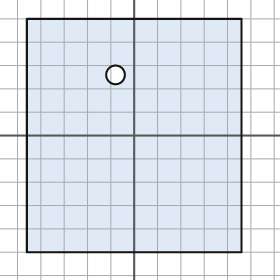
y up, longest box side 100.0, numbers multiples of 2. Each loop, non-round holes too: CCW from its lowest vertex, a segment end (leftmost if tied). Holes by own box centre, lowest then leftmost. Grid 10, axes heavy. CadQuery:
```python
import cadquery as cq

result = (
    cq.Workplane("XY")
    .moveTo(-46.0, -50.0)
    .lineTo(46.0, -50.0)
    .lineTo(46.0, 50.0)
    .lineTo(-46.0, 50.0)
    .close()
    .moveTo(-8.0, 26.0)
    .circle(4.0)
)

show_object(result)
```